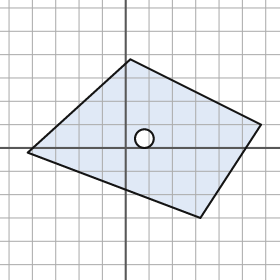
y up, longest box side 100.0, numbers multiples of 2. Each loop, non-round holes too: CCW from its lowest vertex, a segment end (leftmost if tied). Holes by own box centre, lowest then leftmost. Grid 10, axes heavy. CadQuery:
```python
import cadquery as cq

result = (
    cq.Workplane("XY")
    .moveTo(32.0, -30.0)
    .lineTo(58.0, 10.0)
    .lineTo(2.0, 38.0)
    .lineTo(-42.0, -2.0)
    .close()
    .moveTo(8.0, 4.0)
    .circle(4.0)
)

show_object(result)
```